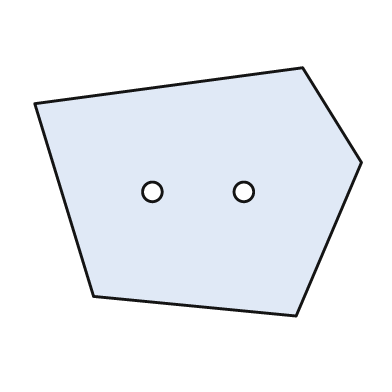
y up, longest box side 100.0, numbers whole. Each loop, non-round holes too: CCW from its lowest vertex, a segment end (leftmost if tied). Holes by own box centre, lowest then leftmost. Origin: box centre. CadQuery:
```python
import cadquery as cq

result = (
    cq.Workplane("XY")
    .moveTo(30.0, -38.0)
    .lineTo(50.0, 9.0)
    .lineTo(32.0, 38.0)
    .lineTo(-50.0, 27.0)
    .lineTo(-32.0, -32.0)
    .close()
    .moveTo(-14.0, 0.0)
    .circle(3.0)
    .moveTo(14.0, 0.0)
    .circle(3.0)
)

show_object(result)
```